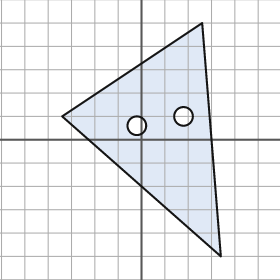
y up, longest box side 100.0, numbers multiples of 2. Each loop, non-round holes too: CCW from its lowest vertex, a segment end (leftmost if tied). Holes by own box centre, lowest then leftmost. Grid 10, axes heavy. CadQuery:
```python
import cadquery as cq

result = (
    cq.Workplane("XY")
    .moveTo(34.0, -50.0)
    .lineTo(26.0, 50.0)
    .lineTo(-34.0, 10.0)
    .close()
    .moveTo(-2.0, 6.0)
    .circle(4.0)
    .moveTo(18.0, 10.0)
    .circle(4.0)
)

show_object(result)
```